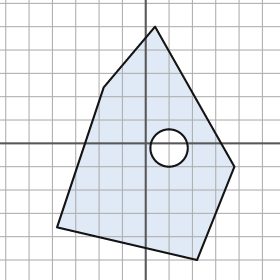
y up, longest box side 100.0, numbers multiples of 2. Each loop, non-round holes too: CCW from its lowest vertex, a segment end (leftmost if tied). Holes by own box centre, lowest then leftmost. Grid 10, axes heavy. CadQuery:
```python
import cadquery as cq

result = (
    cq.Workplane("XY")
    .moveTo(22.0, -50.0)
    .lineTo(38.0, -10.0)
    .lineTo(4.0, 50.0)
    .lineTo(-18.0, 24.0)
    .lineTo(-38.0, -36.0)
    .close()
    .moveTo(10.0, -2.0)
    .circle(8.0)
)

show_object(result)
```